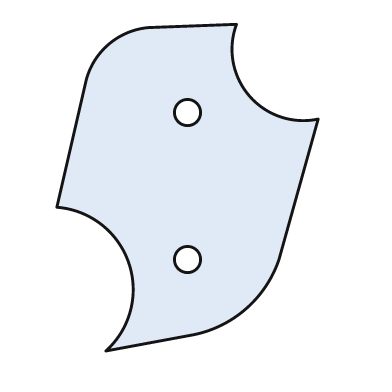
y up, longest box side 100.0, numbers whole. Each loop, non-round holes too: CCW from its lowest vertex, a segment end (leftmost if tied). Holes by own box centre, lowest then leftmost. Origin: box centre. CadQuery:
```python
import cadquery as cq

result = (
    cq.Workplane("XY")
    .moveTo(-25.0, -50.0)
    .lineTo(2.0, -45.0)
    .threePointArc((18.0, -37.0), (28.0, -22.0))
    .lineTo(40.0, 21.0)
    .threePointArc((19.0, 28.0), (15.0, 50.0))
    .lineTo(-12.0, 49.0)
    .threePointArc((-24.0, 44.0), (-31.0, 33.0))
    .lineTo(-40.0, -6.0)
    .threePointArc((-18.0, -23.0), (-25.0, -50.0))
    .close()
    .moveTo(0.0, -22.0)
    .circle(4.0)
    .moveTo(0.0, 23.0)
    .circle(4.0)
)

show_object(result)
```